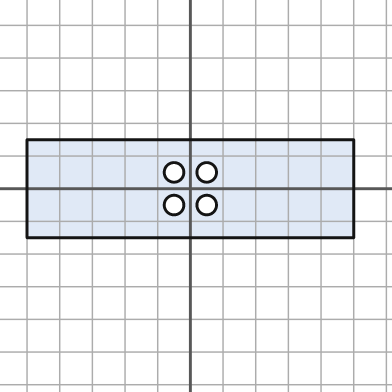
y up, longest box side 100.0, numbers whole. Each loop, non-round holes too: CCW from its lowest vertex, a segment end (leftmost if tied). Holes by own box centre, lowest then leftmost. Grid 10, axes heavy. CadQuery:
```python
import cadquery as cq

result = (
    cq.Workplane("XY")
    .moveTo(-50.0, -15.0)
    .lineTo(50.0, -15.0)
    .lineTo(50.0, 15.0)
    .lineTo(-50.0, 15.0)
    .close()
    .moveTo(-5.0, -5.0)
    .circle(3.0)
    .moveTo(5.0, -5.0)
    .circle(3.0)
    .moveTo(-5.0, 5.0)
    .circle(3.0)
    .moveTo(5.0, 5.0)
    .circle(3.0)
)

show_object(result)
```